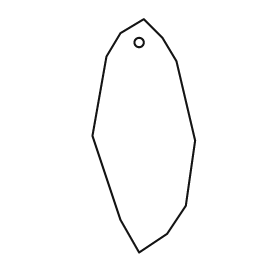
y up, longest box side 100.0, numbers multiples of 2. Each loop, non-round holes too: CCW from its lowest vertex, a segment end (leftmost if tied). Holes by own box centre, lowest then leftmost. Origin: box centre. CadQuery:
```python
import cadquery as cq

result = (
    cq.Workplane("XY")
    .moveTo(-2.0, -50.0)
    .lineTo(10.0, -42.0)
    .lineTo(18.0, -30.0)
    .lineTo(22.0, -2.0)
    .lineTo(14.0, 32.0)
    .lineTo(8.0, 42.0)
    .lineTo(0.0, 50.0)
    .lineTo(-10.0, 44.0)
    .lineTo(-16.0, 34.0)
    .lineTo(-22.0, 0.0)
    .lineTo(-10.0, -36.0)
    .close()
    .moveTo(-2.0, 40.0)
    .circle(2.0)
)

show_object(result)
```